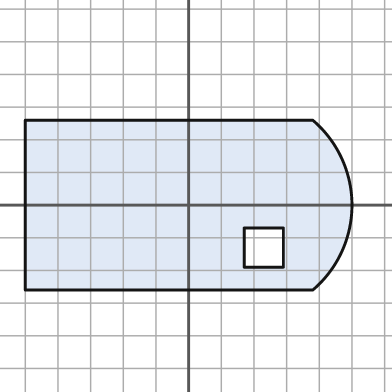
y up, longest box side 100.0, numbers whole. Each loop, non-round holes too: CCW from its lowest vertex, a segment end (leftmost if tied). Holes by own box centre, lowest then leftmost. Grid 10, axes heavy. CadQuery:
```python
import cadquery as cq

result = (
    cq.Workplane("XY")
    .moveTo(-50.0, -26.0)
    .lineTo(38.0, -26.0)
    .threePointArc((50.0, 0.0), (38.0, 26.0))
    .lineTo(-50.0, 26.0)
    .close()
    .moveTo(17.0, -19.0)
    .lineTo(29.0, -19.0)
    .lineTo(29.0, -7.0)
    .lineTo(17.0, -7.0)
    .close()
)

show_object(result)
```